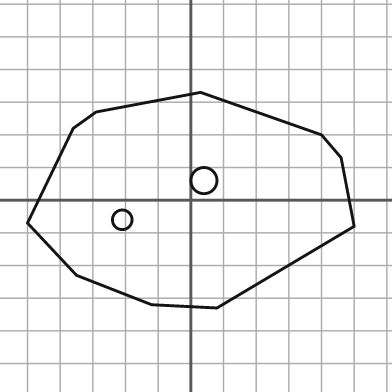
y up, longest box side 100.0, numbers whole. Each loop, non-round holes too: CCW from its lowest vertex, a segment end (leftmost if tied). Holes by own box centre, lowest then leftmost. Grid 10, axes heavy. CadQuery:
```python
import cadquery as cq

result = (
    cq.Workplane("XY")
    .moveTo(8.0, -33.0)
    .lineTo(50.0, -8.0)
    .lineTo(46.0, 13.0)
    .lineTo(40.0, 20.0)
    .lineTo(3.0, 33.0)
    .lineTo(-29.0, 27.0)
    .lineTo(-36.0, 22.0)
    .lineTo(-50.0, -7.0)
    .lineTo(-35.0, -23.0)
    .lineTo(-12.0, -32.0)
    .close()
    .moveTo(-21.0, -6.0)
    .circle(3.0)
    .moveTo(4.0, 6.0)
    .circle(4.0)
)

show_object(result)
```